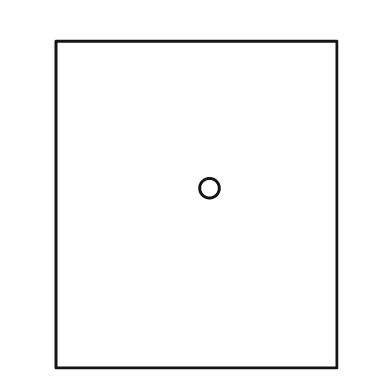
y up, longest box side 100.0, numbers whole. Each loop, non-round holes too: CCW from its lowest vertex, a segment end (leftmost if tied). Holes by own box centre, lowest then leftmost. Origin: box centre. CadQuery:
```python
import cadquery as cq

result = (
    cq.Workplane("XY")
    .moveTo(-43.0, -50.0)
    .lineTo(43.0, -50.0)
    .lineTo(43.0, 50.0)
    .lineTo(-43.0, 50.0)
    .close()
    .moveTo(4.0, 5.0)
    .circle(3.0)
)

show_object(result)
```